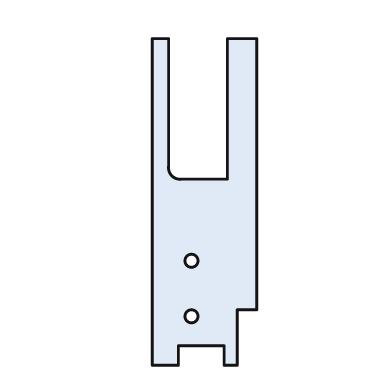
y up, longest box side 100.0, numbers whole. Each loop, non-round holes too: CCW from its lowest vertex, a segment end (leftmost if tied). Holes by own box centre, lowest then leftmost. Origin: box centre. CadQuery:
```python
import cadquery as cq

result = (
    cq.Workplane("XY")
    .moveTo(-16.0, -50.0)
    .lineTo(-8.0, -50.0)
    .lineTo(-8.0, -44.0)
    .lineTo(6.0, -44.0)
    .lineTo(6.0, -50.0)
    .lineTo(10.0, -50.0)
    .lineTo(10.0, -33.0)
    .lineTo(16.0, -33.0)
    .lineTo(16.0, 50.0)
    .lineTo(7.0, 50.0)
    .lineTo(7.0, 7.0)
    .lineTo(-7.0, 7.0)
    .threePointArc((-10.0, 8.0), (-11.0, 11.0))
    .lineTo(-11.0, 50.0)
    .lineTo(-16.0, 50.0)
    .close()
    .moveTo(-4.0, -35.0)
    .circle(2.0)
    .moveTo(-4.0, -18.0)
    .circle(2.0)
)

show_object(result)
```